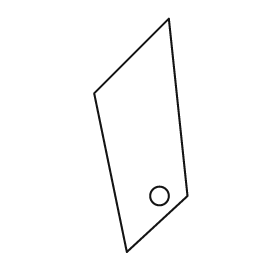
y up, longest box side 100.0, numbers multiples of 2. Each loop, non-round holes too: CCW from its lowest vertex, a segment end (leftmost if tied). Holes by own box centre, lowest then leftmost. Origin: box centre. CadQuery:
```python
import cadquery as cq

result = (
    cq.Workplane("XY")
    .moveTo(-6.0, -50.0)
    .lineTo(20.0, -26.0)
    .lineTo(12.0, 50.0)
    .lineTo(-20.0, 18.0)
    .close()
    .moveTo(8.0, -26.0)
    .circle(4.0)
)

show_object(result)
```